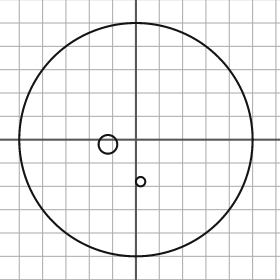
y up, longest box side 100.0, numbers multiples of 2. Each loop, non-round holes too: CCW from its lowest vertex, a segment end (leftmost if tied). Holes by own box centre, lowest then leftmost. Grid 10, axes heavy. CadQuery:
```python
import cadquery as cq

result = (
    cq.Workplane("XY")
    .moveTo(0.0, 0.0)
    .circle(50.0)
    .moveTo(2.0, -18.0)
    .circle(2.0)
    .moveTo(-12.0, -2.0)
    .circle(4.0)
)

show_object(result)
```